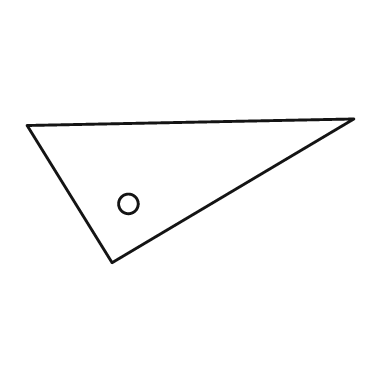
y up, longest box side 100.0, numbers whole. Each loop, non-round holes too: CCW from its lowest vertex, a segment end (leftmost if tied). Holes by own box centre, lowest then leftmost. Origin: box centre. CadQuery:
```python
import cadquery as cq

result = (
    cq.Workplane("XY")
    .moveTo(-24.0, -22.0)
    .lineTo(50.0, 22.0)
    .lineTo(-50.0, 20.0)
    .close()
    .moveTo(-19.0, -4.0)
    .circle(3.0)
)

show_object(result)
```